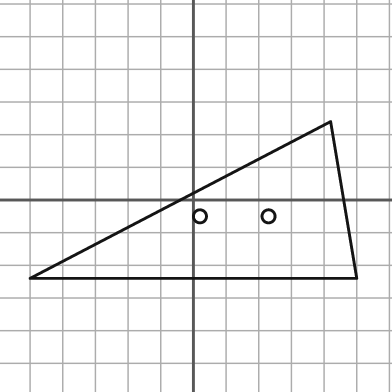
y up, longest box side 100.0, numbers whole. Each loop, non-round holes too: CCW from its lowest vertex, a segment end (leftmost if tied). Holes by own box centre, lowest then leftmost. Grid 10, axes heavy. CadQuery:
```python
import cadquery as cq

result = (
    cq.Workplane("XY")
    .moveTo(-50.0, -24.0)
    .lineTo(50.0, -24.0)
    .lineTo(42.0, 24.0)
    .close()
    .moveTo(2.0, -5.0)
    .circle(2.0)
    .moveTo(23.0, -5.0)
    .circle(2.0)
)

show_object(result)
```